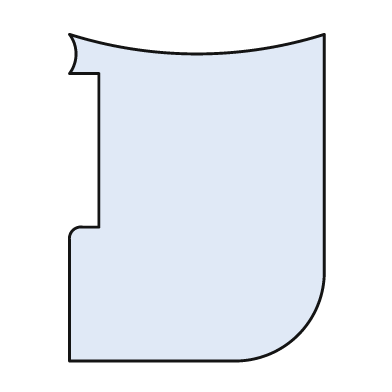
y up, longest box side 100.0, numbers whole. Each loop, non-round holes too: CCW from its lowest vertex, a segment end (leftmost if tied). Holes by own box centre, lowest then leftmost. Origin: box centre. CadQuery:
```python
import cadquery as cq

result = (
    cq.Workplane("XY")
    .moveTo(-39.0, -50.0)
    .lineTo(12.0, -50.0)
    .threePointArc((31.0, -42.0), (39.0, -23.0))
    .lineTo(39.0, 50.0)
    .threePointArc((0.0, 44.0), (-39.0, 50.0))
    .threePointArc((-37.0, 44.0), (-39.0, 38.0))
    .lineTo(-30.0, 38.0)
    .lineTo(-30.0, -9.0)
    .lineTo(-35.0, -9.0)
    .threePointArc((-38.0, -10.0), (-39.0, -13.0))
    .close()
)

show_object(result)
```